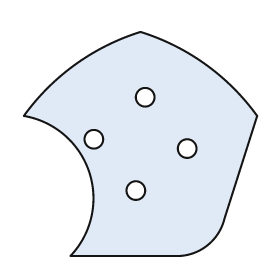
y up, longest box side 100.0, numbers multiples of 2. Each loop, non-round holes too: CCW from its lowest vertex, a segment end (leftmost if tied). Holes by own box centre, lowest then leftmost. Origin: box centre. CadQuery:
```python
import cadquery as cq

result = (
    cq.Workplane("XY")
    .moveTo(-30.0, -48.0)
    .lineTo(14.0, -48.0)
    .threePointArc((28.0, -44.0), (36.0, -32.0))
    .lineTo(50.0, 12.0)
    .threePointArc((28.0, 34.0), (0.0, 48.0))
    .threePointArc((-28.0, 34.0), (-50.0, 12.0))
    .threePointArc((-22.0, -12.0), (-30.0, -48.0))
    .close()
    .moveTo(-2.0, -20.0)
    .circle(4.0)
    .moveTo(20.0, -2.0)
    .circle(4.0)
    .moveTo(-20.0, 2.0)
    .circle(4.0)
    .moveTo(2.0, 20.0)
    .circle(4.0)
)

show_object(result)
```